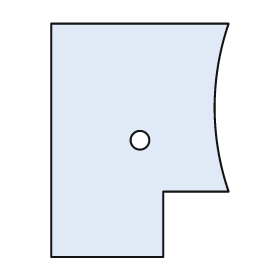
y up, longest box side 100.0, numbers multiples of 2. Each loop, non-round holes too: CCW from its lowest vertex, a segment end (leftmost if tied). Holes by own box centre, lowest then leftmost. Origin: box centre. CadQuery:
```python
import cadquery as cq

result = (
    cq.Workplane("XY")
    .moveTo(-38.0, -50.0)
    .lineTo(10.0, -50.0)
    .lineTo(10.0, -22.0)
    .lineTo(38.0, -22.0)
    .threePointArc((32.0, 14.0), (38.0, 50.0))
    .lineTo(-38.0, 50.0)
    .close()
    .moveTo(0.0, 0.0)
    .circle(4.0)
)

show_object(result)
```